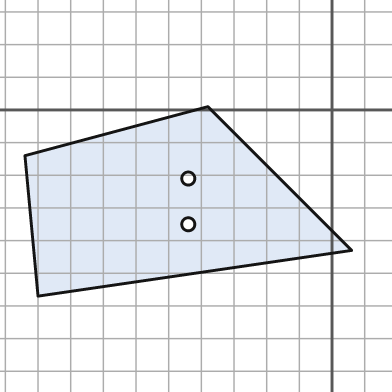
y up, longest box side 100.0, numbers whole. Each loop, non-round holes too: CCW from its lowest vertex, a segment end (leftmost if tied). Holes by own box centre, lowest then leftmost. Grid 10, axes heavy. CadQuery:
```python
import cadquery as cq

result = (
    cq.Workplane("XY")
    .moveTo(-90.0, -57.0)
    .lineTo(6.0, -43.0)
    .lineTo(-38.0, 1.0)
    .lineTo(-94.0, -14.0)
    .close()
    .moveTo(-44.0, -35.0)
    .circle(2.0)
    .moveTo(-44.0, -21.0)
    .circle(2.0)
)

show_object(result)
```